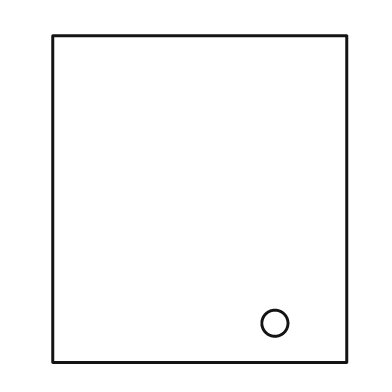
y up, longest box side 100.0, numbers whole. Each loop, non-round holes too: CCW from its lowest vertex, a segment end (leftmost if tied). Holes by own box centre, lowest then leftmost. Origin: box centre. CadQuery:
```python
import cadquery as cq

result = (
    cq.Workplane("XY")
    .moveTo(-45.0, -50.0)
    .lineTo(45.0, -50.0)
    .lineTo(45.0, 50.0)
    .lineTo(-45.0, 50.0)
    .close()
    .moveTo(23.0, -38.0)
    .circle(4.0)
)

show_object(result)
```